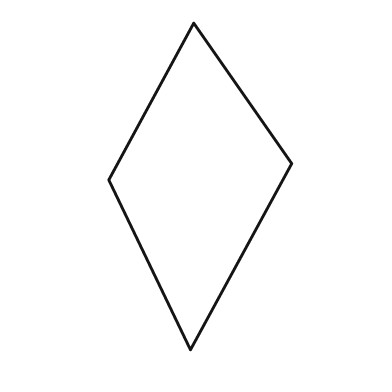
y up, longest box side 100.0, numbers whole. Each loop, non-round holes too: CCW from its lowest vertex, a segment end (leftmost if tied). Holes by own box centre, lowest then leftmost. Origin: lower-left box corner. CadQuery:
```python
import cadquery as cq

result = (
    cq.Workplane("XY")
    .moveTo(25.0, 0.0)
    .lineTo(56.0, 57.0)
    .lineTo(26.0, 100.0)
    .lineTo(0.0, 52.0)
    .close()
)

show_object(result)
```